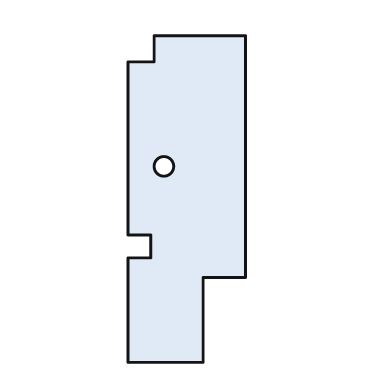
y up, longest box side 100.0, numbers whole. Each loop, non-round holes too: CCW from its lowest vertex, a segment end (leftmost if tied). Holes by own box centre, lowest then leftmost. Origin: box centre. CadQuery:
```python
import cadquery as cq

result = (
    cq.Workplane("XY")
    .moveTo(-18.0, -50.0)
    .lineTo(5.0, -50.0)
    .lineTo(5.0, -24.0)
    .lineTo(18.0, -24.0)
    .lineTo(18.0, 50.0)
    .lineTo(-10.0, 50.0)
    .lineTo(-10.0, 42.0)
    .lineTo(-18.0, 42.0)
    .lineTo(-18.0, -11.0)
    .lineTo(-11.0, -11.0)
    .lineTo(-11.0, -18.0)
    .lineTo(-18.0, -18.0)
    .close()
    .moveTo(-7.0, 10.0)
    .circle(3.0)
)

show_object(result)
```